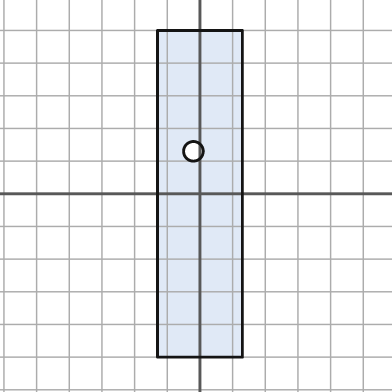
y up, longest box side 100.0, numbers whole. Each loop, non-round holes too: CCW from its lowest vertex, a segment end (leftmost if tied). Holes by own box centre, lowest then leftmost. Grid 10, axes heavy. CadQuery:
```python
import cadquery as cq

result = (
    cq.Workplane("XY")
    .moveTo(-13.0, -50.0)
    .lineTo(13.0, -50.0)
    .lineTo(13.0, 50.0)
    .lineTo(-13.0, 50.0)
    .close()
    .moveTo(-2.0, 13.0)
    .circle(3.0)
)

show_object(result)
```